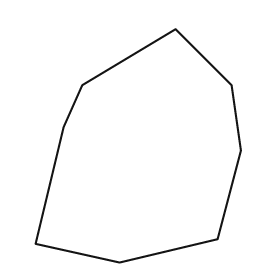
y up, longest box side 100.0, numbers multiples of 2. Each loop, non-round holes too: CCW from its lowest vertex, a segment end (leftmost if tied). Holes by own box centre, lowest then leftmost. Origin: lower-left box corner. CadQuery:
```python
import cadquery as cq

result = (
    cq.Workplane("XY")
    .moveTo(36.0, 0.0)
    .lineTo(78.0, 10.0)
    .lineTo(88.0, 48.0)
    .lineTo(84.0, 76.0)
    .lineTo(60.0, 100.0)
    .lineTo(20.0, 76.0)
    .lineTo(12.0, 58.0)
    .lineTo(0.0, 8.0)
    .close()
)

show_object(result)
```